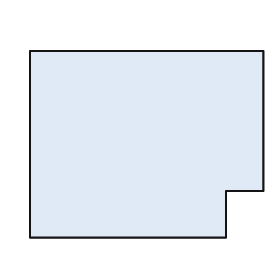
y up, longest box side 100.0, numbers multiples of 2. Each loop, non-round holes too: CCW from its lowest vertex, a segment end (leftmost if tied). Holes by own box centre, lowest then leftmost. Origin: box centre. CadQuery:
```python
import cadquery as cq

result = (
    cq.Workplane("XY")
    .moveTo(-50.0, -40.0)
    .lineTo(34.0, -40.0)
    .lineTo(34.0, -20.0)
    .lineTo(50.0, -20.0)
    .lineTo(50.0, 40.0)
    .lineTo(-50.0, 40.0)
    .close()
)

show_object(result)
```